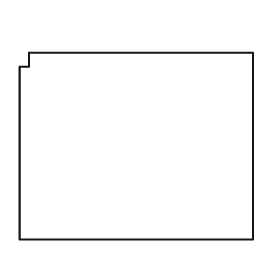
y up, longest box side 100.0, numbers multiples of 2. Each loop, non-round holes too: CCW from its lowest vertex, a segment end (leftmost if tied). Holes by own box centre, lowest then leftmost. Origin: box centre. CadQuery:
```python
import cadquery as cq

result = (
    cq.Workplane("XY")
    .moveTo(-50.0, -40.0)
    .lineTo(50.0, -40.0)
    .lineTo(50.0, 40.0)
    .lineTo(-46.0, 40.0)
    .lineTo(-46.0, 34.0)
    .lineTo(-50.0, 34.0)
    .close()
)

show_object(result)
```